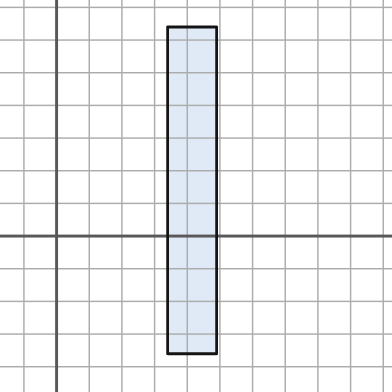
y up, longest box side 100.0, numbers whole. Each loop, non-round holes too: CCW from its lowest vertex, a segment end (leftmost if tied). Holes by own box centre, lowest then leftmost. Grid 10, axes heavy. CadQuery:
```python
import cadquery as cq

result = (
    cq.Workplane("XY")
    .moveTo(34.0, -36.0)
    .lineTo(49.0, -36.0)
    .lineTo(49.0, 64.0)
    .lineTo(34.0, 64.0)
    .close()
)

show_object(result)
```